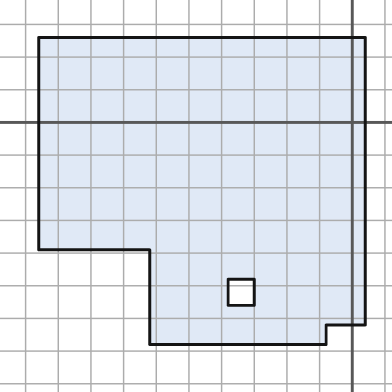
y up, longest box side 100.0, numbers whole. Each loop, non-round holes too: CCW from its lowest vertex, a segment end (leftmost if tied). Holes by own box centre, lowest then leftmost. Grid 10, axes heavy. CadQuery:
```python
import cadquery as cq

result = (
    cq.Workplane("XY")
    .moveTo(-62.0, -68.0)
    .lineTo(-8.0, -68.0)
    .lineTo(-8.0, -62.0)
    .lineTo(4.0, -62.0)
    .lineTo(4.0, 26.0)
    .lineTo(-96.0, 26.0)
    .lineTo(-96.0, -39.0)
    .lineTo(-62.0, -39.0)
    .close()
    .moveTo(-38.0, -56.0)
    .lineTo(-30.0, -56.0)
    .lineTo(-30.0, -48.0)
    .lineTo(-38.0, -48.0)
    .close()
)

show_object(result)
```